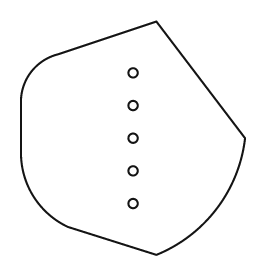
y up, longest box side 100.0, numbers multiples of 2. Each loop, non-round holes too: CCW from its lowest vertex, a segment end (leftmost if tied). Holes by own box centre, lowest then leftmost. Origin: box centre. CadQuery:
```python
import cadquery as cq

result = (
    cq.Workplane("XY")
    .moveTo(10.0, -50.0)
    .threePointArc((36.0, -30.0), (48.0, 0.0))
    .lineTo(10.0, 50.0)
    .lineTo(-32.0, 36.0)
    .threePointArc((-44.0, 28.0), (-48.0, 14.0))
    .lineTo(-48.0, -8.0)
    .threePointArc((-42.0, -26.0), (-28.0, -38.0))
    .close()
    .moveTo(0.0, -28.0)
    .circle(2.0)
    .moveTo(0.0, -14.0)
    .circle(2.0)
    .moveTo(0.0, 0.0)
    .circle(2.0)
    .moveTo(0.0, 14.0)
    .circle(2.0)
    .moveTo(0.0, 28.0)
    .circle(2.0)
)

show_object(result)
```